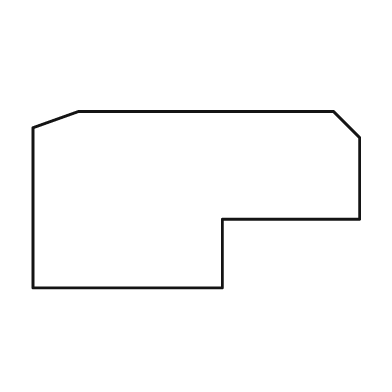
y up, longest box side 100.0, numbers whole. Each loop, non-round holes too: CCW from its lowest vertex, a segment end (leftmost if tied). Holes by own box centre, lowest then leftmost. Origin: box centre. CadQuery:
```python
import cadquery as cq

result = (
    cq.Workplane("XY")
    .moveTo(-50.0, -27.0)
    .lineTo(8.0, -27.0)
    .lineTo(8.0, -6.0)
    .lineTo(50.0, -6.0)
    .lineTo(50.0, 19.0)
    .lineTo(42.0, 27.0)
    .lineTo(-36.0, 27.0)
    .lineTo(-50.0, 22.0)
    .close()
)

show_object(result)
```